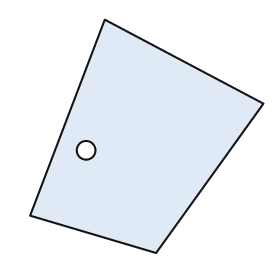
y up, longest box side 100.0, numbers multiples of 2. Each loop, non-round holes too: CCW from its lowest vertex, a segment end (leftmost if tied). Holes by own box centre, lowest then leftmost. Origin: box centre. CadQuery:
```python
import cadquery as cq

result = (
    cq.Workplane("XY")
    .moveTo(4.0, -50.0)
    .lineTo(50.0, 14.0)
    .lineTo(-18.0, 50.0)
    .lineTo(-50.0, -34.0)
    .close()
    .moveTo(-26.0, -6.0)
    .circle(4.0)
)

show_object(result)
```